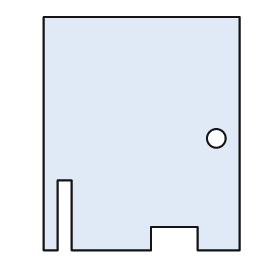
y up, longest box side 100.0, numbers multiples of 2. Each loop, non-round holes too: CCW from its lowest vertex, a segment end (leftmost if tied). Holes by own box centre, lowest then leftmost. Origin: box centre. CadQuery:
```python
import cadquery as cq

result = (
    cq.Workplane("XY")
    .moveTo(-42.0, -50.0)
    .lineTo(-36.0, -50.0)
    .lineTo(-36.0, -20.0)
    .lineTo(-30.0, -20.0)
    .lineTo(-30.0, -50.0)
    .lineTo(4.0, -50.0)
    .lineTo(4.0, -40.0)
    .lineTo(24.0, -40.0)
    .lineTo(24.0, -50.0)
    .lineTo(42.0, -50.0)
    .lineTo(42.0, 50.0)
    .lineTo(-42.0, 50.0)
    .close()
    .moveTo(32.0, -2.0)
    .circle(4.0)
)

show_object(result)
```